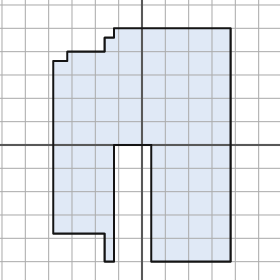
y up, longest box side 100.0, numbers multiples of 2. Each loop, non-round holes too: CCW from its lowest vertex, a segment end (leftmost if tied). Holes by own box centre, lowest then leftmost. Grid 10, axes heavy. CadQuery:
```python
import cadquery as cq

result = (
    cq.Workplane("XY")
    .moveTo(-16.0, -50.0)
    .lineTo(-12.0, -50.0)
    .lineTo(-12.0, 0.0)
    .lineTo(4.0, 0.0)
    .lineTo(4.0, -50.0)
    .lineTo(38.0, -50.0)
    .lineTo(38.0, 50.0)
    .lineTo(-12.0, 50.0)
    .lineTo(-12.0, 46.0)
    .lineTo(-16.0, 46.0)
    .lineTo(-16.0, 40.0)
    .lineTo(-32.0, 40.0)
    .lineTo(-32.0, 36.0)
    .lineTo(-38.0, 36.0)
    .lineTo(-38.0, -38.0)
    .lineTo(-16.0, -38.0)
    .close()
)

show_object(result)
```